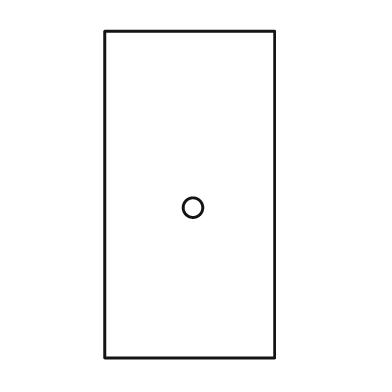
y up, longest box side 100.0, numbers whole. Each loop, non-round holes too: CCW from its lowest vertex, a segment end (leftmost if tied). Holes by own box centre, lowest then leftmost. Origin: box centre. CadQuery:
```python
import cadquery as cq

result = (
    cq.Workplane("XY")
    .moveTo(-26.0, -50.0)
    .lineTo(26.0, -50.0)
    .lineTo(26.0, 50.0)
    .lineTo(-26.0, 50.0)
    .close()
    .moveTo(1.0, -4.0)
    .circle(3.0)
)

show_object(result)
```